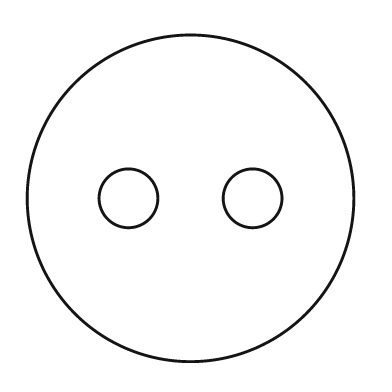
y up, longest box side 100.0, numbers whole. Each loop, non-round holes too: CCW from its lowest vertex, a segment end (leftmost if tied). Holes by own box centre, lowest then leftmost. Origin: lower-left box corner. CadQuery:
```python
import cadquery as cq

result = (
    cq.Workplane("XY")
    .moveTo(50.0, 50.0)
    .circle(50.0)
    .moveTo(31.0, 50.0)
    .circle(9.0)
    .moveTo(69.0, 50.0)
    .circle(9.0)
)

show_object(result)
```